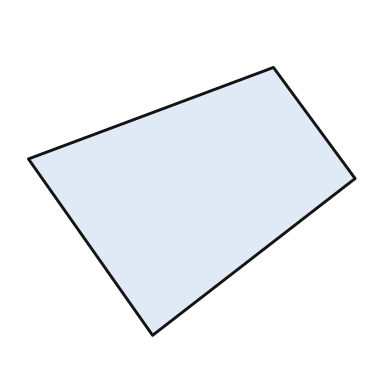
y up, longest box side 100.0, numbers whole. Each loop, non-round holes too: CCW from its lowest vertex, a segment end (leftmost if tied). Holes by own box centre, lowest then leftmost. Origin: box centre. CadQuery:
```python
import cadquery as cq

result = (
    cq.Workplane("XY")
    .moveTo(-12.0, -41.0)
    .lineTo(50.0, 7.0)
    .lineTo(25.0, 41.0)
    .lineTo(-50.0, 13.0)
    .close()
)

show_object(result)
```